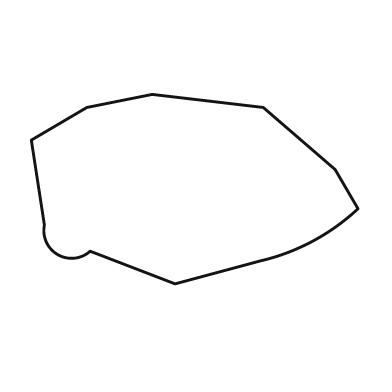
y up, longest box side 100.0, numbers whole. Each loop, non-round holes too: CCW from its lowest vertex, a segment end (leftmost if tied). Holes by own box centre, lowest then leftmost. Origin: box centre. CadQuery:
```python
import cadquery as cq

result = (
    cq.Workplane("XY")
    .moveTo(-6.0, -29.0)
    .lineTo(20.0, -22.0)
    .threePointArc((36.0, -16.0), (50.0, -6.0))
    .lineTo(43.0, 6.0)
    .lineTo(21.0, 25.0)
    .lineTo(-13.0, 29.0)
    .lineTo(-33.0, 25.0)
    .lineTo(-50.0, 15.0)
    .lineTo(-46.0, -11.0)
    .threePointArc((-42.0, -20.0), (-32.0, -19.0))
    .close()
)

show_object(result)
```